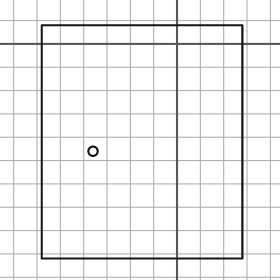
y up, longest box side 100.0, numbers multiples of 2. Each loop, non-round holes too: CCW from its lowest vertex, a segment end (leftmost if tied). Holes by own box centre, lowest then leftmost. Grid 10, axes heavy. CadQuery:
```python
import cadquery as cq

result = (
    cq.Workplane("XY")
    .moveTo(-58.0, -92.0)
    .lineTo(28.0, -92.0)
    .lineTo(28.0, 8.0)
    .lineTo(-58.0, 8.0)
    .close()
    .moveTo(-36.0, -46.0)
    .circle(2.0)
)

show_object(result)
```